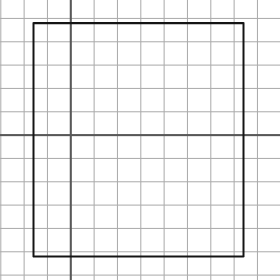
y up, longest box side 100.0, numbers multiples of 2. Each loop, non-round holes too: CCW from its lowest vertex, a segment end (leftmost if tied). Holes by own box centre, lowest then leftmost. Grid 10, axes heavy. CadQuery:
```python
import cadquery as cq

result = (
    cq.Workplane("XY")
    .moveTo(-16.0, -52.0)
    .lineTo(74.0, -52.0)
    .lineTo(74.0, 48.0)
    .lineTo(-16.0, 48.0)
    .close()
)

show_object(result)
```